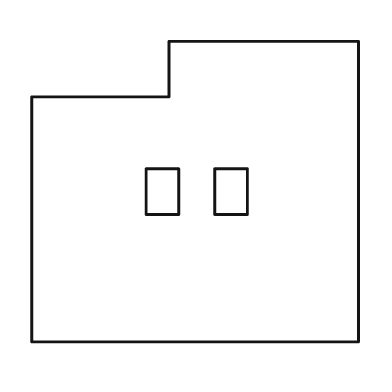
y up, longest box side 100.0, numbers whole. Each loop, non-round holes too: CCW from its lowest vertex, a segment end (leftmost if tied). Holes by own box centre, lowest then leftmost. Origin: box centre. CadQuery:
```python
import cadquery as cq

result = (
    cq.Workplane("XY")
    .moveTo(-50.0, -46.0)
    .lineTo(50.0, -46.0)
    .lineTo(50.0, 46.0)
    .lineTo(-8.0, 46.0)
    .lineTo(-8.0, 29.0)
    .lineTo(-50.0, 29.0)
    .close()
    .moveTo(-15.0, -7.0)
    .lineTo(-5.0, -7.0)
    .lineTo(-5.0, 7.0)
    .lineTo(-15.0, 7.0)
    .close()
    .moveTo(6.0, -7.0)
    .lineTo(16.0, -7.0)
    .lineTo(16.0, 7.0)
    .lineTo(6.0, 7.0)
    .close()
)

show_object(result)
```